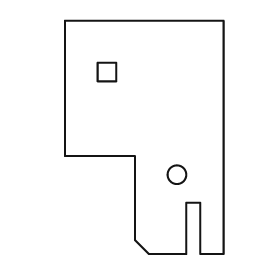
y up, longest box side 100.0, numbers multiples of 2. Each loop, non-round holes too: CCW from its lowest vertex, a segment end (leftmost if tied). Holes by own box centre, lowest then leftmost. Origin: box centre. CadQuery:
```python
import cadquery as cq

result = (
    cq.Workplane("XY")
    .moveTo(2.0, -50.0)
    .lineTo(18.0, -50.0)
    .lineTo(18.0, -28.0)
    .lineTo(24.0, -28.0)
    .lineTo(24.0, -50.0)
    .lineTo(34.0, -50.0)
    .lineTo(34.0, 50.0)
    .lineTo(-34.0, 50.0)
    .lineTo(-34.0, -8.0)
    .lineTo(-4.0, -8.0)
    .lineTo(-4.0, -44.0)
    .close()
    .moveTo(14.0, -16.0)
    .circle(4.0)
    .moveTo(-20.0, 24.0)
    .lineTo(-12.0, 24.0)
    .lineTo(-12.0, 32.0)
    .lineTo(-20.0, 32.0)
    .close()
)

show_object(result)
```